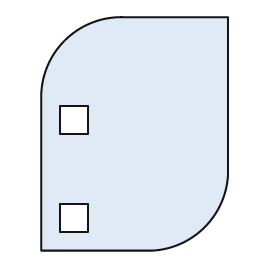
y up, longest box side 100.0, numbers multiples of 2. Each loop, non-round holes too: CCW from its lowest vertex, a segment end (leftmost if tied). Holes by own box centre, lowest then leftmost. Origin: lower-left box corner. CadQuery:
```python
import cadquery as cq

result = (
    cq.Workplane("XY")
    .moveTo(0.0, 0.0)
    .lineTo(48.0, 0.0)
    .threePointArc((70.0, 10.0), (80.0, 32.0))
    .lineTo(80.0, 100.0)
    .lineTo(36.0, 100.0)
    .threePointArc((10.0, 90.0), (0.0, 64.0))
    .close()
    .moveTo(8.0, 8.0)
    .lineTo(20.0, 8.0)
    .lineTo(20.0, 20.0)
    .lineTo(8.0, 20.0)
    .close()
    .moveTo(8.0, 50.0)
    .lineTo(20.0, 50.0)
    .lineTo(20.0, 62.0)
    .lineTo(8.0, 62.0)
    .close()
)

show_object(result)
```